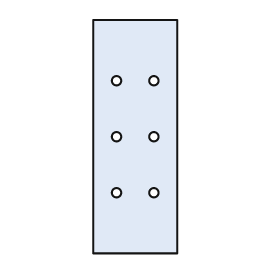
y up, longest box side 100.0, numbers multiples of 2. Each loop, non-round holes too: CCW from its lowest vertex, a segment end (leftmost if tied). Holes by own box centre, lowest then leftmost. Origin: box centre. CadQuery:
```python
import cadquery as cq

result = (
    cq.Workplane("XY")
    .moveTo(-18.0, -50.0)
    .lineTo(18.0, -50.0)
    .lineTo(18.0, 50.0)
    .lineTo(-18.0, 50.0)
    .close()
    .moveTo(-8.0, -24.0)
    .circle(2.0)
    .moveTo(8.0, -24.0)
    .circle(2.0)
    .moveTo(-8.0, 0.0)
    .circle(2.0)
    .moveTo(8.0, 0.0)
    .circle(2.0)
    .moveTo(-8.0, 24.0)
    .circle(2.0)
    .moveTo(8.0, 24.0)
    .circle(2.0)
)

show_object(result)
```